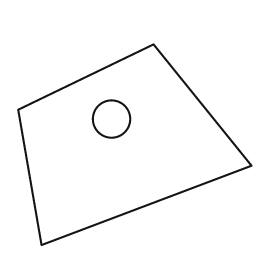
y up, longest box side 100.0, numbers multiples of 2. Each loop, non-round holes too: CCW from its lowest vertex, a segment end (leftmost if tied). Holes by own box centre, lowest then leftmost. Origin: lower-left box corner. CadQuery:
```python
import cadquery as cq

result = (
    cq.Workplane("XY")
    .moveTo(10.0, 0.0)
    .lineTo(100.0, 34.0)
    .lineTo(58.0, 86.0)
    .lineTo(0.0, 58.0)
    .close()
    .moveTo(40.0, 54.0)
    .circle(8.0)
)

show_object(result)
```